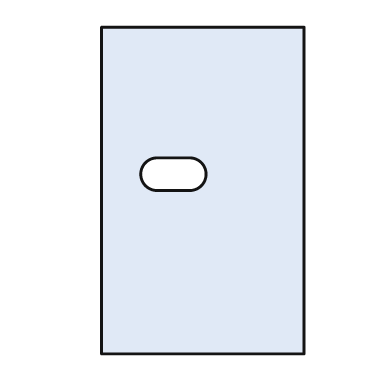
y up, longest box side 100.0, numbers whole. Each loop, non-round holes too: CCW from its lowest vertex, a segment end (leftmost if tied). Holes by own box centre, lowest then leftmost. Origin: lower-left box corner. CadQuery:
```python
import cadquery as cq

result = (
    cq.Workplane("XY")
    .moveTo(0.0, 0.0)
    .lineTo(62.0, 0.0)
    .lineTo(62.0, 100.0)
    .lineTo(0.0, 100.0)
    .close()
    .moveTo(17.0, 50.0)
    .lineTo(27.0, 50.0)
    .threePointArc((32.0, 55.0), (27.0, 60.0))
    .lineTo(17.0, 60.0)
    .threePointArc((12.0, 55.0), (17.0, 50.0))
    .close()
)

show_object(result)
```